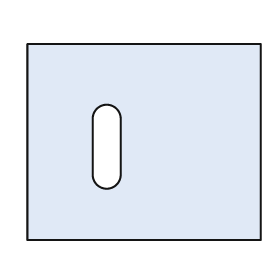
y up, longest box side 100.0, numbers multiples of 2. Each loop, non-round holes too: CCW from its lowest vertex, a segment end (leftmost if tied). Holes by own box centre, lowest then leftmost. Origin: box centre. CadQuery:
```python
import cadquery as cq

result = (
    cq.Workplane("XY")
    .moveTo(-50.0, -42.0)
    .lineTo(50.0, -42.0)
    .lineTo(50.0, 42.0)
    .lineTo(-50.0, 42.0)
    .close()
    .moveTo(-22.0, -14.0)
    .threePointArc((-16.0, -20.0), (-10.0, -14.0))
    .lineTo(-10.0, 10.0)
    .threePointArc((-16.0, 16.0), (-22.0, 10.0))
    .close()
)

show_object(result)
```